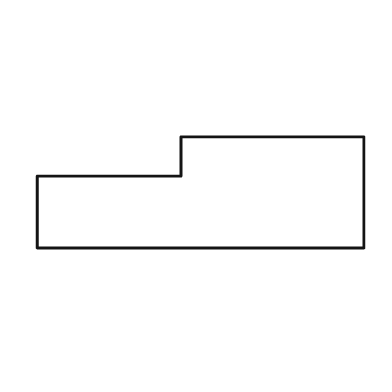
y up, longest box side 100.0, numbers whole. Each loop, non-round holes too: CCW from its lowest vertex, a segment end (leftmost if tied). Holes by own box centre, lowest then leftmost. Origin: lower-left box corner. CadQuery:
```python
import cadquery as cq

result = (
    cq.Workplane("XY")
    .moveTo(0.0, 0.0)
    .lineTo(100.0, 0.0)
    .lineTo(100.0, 34.0)
    .lineTo(44.0, 34.0)
    .lineTo(44.0, 22.0)
    .lineTo(0.0, 22.0)
    .close()
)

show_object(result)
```